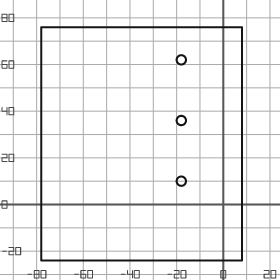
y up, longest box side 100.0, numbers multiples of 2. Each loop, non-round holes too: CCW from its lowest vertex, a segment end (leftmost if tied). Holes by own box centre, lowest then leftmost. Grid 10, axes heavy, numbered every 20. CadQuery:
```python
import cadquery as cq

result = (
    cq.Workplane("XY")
    .moveTo(-78.0, -24.0)
    .lineTo(8.0, -24.0)
    .lineTo(8.0, 76.0)
    .lineTo(-78.0, 76.0)
    .close()
    .moveTo(-18.0, 10.0)
    .circle(2.0)
    .moveTo(-18.0, 36.0)
    .circle(2.0)
    .moveTo(-18.0, 62.0)
    .circle(2.0)
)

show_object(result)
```